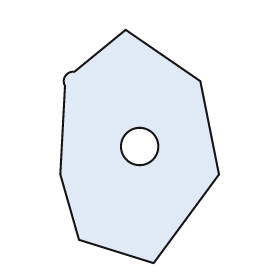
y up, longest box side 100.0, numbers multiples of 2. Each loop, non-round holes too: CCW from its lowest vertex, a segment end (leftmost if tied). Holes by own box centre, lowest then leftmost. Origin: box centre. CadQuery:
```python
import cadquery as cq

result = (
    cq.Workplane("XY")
    .moveTo(6.0, -50.0)
    .lineTo(34.0, -12.0)
    .lineTo(26.0, 28.0)
    .lineTo(-6.0, 50.0)
    .lineTo(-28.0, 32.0)
    .threePointArc((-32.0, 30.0), (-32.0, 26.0))
    .lineTo(-34.0, -12.0)
    .lineTo(-26.0, -40.0)
    .close()
    .moveTo(0.0, 0.0)
    .circle(8.0)
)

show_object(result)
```